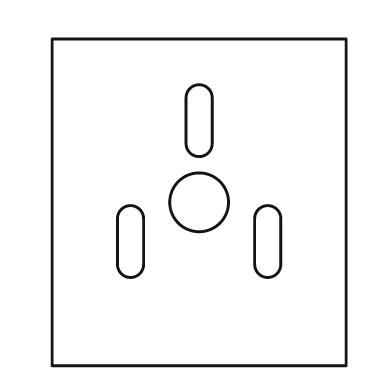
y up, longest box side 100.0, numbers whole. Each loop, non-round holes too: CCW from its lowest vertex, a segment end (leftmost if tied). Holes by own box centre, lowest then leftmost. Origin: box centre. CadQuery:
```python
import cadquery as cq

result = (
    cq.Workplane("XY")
    .moveTo(-45.0, -50.0)
    .lineTo(45.0, -50.0)
    .lineTo(45.0, 50.0)
    .lineTo(-45.0, 50.0)
    .close()
    .moveTo(-25.0, -19.0)
    .threePointArc((-21.0, -23.0), (-17.0, -19.0))
    .lineTo(-17.0, -5.0)
    .threePointArc((-21.0, -1.0), (-25.0, -5.0))
    .close()
    .moveTo(17.0, -19.0)
    .threePointArc((21.0, -23.0), (25.0, -19.0))
    .lineTo(25.0, -5.0)
    .threePointArc((21.0, -1.0), (17.0, -5.0))
    .close()
    .moveTo(0.0, 0.0)
    .circle(9.0)
    .moveTo(-4.0, 18.0)
    .threePointArc((0.0, 14.0), (4.0, 18.0))
    .lineTo(4.0, 32.0)
    .threePointArc((0.0, 36.0), (-4.0, 32.0))
    .close()
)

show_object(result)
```